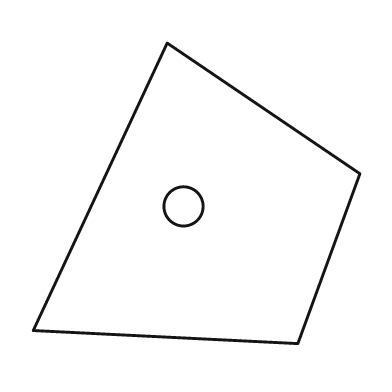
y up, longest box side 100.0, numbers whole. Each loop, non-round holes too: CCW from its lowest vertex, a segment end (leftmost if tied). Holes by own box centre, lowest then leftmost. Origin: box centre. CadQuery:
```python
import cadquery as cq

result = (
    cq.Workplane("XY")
    .moveTo(31.0, -46.0)
    .lineTo(50.0, 6.0)
    .lineTo(-9.0, 46.0)
    .lineTo(-50.0, -42.0)
    .close()
    .moveTo(-4.0, -4.0)
    .circle(6.0)
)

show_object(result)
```